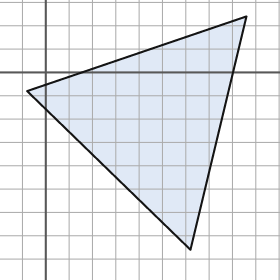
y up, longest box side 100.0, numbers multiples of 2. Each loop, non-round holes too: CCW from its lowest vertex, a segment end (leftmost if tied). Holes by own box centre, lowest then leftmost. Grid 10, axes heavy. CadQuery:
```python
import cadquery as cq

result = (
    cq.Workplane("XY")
    .moveTo(62.0, -76.0)
    .lineTo(86.0, 24.0)
    .lineTo(-8.0, -8.0)
    .close()
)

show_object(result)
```